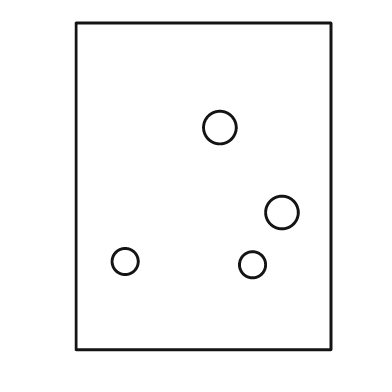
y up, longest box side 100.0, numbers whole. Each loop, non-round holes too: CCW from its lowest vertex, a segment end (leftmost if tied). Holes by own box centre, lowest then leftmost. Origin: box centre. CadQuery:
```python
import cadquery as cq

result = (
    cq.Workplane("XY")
    .moveTo(-39.0, -50.0)
    .lineTo(39.0, -50.0)
    .lineTo(39.0, 50.0)
    .lineTo(-39.0, 50.0)
    .close()
    .moveTo(15.0, -24.0)
    .circle(4.0)
    .moveTo(-24.0, -23.0)
    .circle(4.0)
    .moveTo(24.0, -8.0)
    .circle(5.0)
    .moveTo(5.0, 18.0)
    .circle(5.0)
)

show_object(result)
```